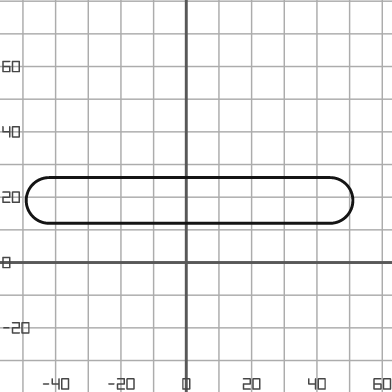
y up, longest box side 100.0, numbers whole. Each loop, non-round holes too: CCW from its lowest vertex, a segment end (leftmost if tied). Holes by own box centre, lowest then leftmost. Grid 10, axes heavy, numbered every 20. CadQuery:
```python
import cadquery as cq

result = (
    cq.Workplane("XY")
    .moveTo(-42.0, 12.0)
    .lineTo(44.0, 12.0)
    .threePointArc((51.0, 19.0), (44.0, 26.0))
    .lineTo(-42.0, 26.0)
    .threePointArc((-49.0, 19.0), (-42.0, 12.0))
    .close()
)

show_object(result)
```